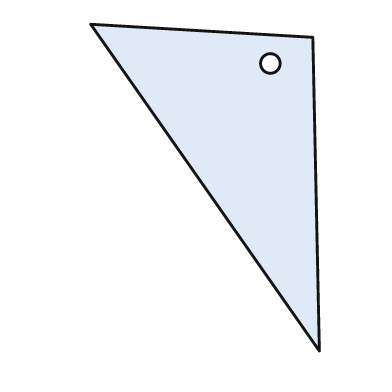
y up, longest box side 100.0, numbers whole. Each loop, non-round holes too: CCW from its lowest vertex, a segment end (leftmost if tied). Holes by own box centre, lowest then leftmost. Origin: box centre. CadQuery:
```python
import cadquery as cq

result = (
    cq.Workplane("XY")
    .moveTo(35.0, -50.0)
    .lineTo(33.0, 46.0)
    .lineTo(-35.0, 50.0)
    .close()
    .moveTo(20.0, 38.0)
    .circle(3.0)
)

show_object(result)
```